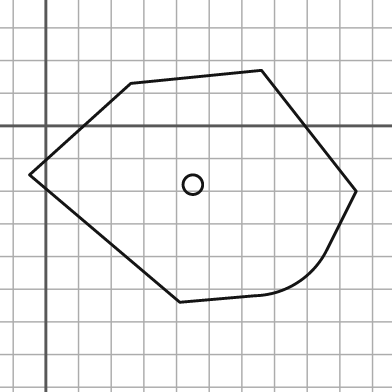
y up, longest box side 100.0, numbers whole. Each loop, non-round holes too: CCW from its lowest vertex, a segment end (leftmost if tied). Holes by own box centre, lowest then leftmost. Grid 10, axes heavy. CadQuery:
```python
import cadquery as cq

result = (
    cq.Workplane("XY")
    .moveTo(41.0, -54.0)
    .lineTo(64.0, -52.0)
    .threePointArc((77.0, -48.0), (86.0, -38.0))
    .lineTo(95.0, -20.0)
    .lineTo(66.0, 17.0)
    .lineTo(26.0, 13.0)
    .lineTo(-5.0, -15.0)
    .close()
    .moveTo(45.0, -18.0)
    .circle(3.0)
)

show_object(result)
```